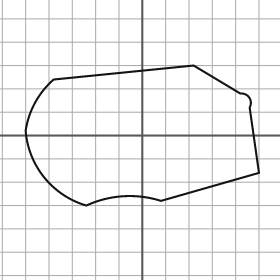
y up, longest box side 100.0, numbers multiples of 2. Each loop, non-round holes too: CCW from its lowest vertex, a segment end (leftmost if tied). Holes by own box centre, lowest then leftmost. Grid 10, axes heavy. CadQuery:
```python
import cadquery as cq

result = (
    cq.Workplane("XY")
    .moveTo(-24.0, -30.0)
    .threePointArc((-8.0, -26.0), (8.0, -28.0))
    .lineTo(50.0, -16.0)
    .lineTo(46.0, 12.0)
    .threePointArc((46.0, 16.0), (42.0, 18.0))
    .lineTo(22.0, 30.0)
    .lineTo(-38.0, 24.0)
    .threePointArc((-46.0, 14.0), (-50.0, 2.0))
    .threePointArc((-42.0, -18.0), (-24.0, -30.0))
    .close()
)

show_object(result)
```